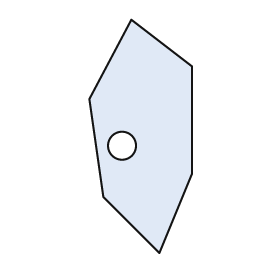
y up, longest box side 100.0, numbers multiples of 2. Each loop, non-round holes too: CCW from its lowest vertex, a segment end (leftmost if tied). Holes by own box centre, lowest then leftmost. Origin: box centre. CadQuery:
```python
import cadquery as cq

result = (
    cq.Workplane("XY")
    .moveTo(8.0, -50.0)
    .lineTo(22.0, -16.0)
    .lineTo(22.0, 30.0)
    .lineTo(-4.0, 50.0)
    .lineTo(-22.0, 16.0)
    .lineTo(-16.0, -26.0)
    .close()
    .moveTo(-8.0, -4.0)
    .circle(6.0)
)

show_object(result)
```